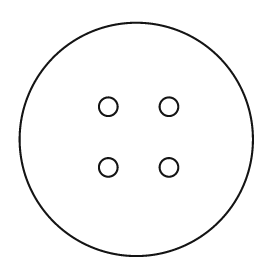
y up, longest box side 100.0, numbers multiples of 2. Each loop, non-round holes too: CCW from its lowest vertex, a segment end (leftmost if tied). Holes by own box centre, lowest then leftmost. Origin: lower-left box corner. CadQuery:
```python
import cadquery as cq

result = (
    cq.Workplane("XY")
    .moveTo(50.0, 50.0)
    .circle(50.0)
    .moveTo(38.0, 38.0)
    .circle(4.0)
    .moveTo(64.0, 38.0)
    .circle(4.0)
    .moveTo(38.0, 64.0)
    .circle(4.0)
    .moveTo(64.0, 64.0)
    .circle(4.0)
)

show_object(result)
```